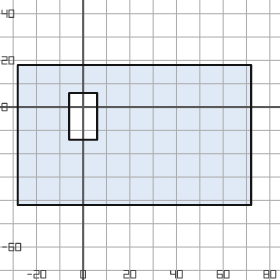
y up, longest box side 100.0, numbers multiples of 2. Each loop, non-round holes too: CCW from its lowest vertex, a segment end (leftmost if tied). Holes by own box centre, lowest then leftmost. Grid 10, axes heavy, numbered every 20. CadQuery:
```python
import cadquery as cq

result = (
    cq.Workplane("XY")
    .moveTo(-28.0, -42.0)
    .lineTo(72.0, -42.0)
    .lineTo(72.0, 18.0)
    .lineTo(-28.0, 18.0)
    .close()
    .moveTo(-6.0, -14.0)
    .lineTo(6.0, -14.0)
    .lineTo(6.0, 6.0)
    .lineTo(-6.0, 6.0)
    .close()
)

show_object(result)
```